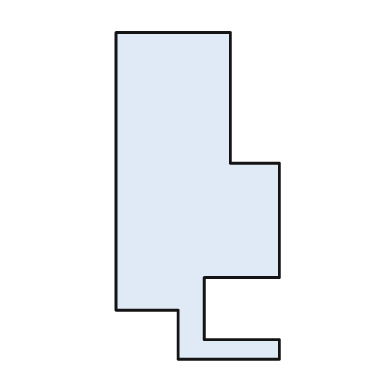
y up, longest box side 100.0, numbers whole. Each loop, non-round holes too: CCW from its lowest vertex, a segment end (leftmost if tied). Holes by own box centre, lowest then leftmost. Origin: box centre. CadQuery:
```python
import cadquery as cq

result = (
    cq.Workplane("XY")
    .moveTo(-6.0, -50.0)
    .lineTo(25.0, -50.0)
    .lineTo(25.0, -44.0)
    .lineTo(2.0, -44.0)
    .lineTo(2.0, -25.0)
    .lineTo(25.0, -25.0)
    .lineTo(25.0, 10.0)
    .lineTo(10.0, 10.0)
    .lineTo(10.0, 50.0)
    .lineTo(-25.0, 50.0)
    .lineTo(-25.0, -35.0)
    .lineTo(-6.0, -35.0)
    .close()
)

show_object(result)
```